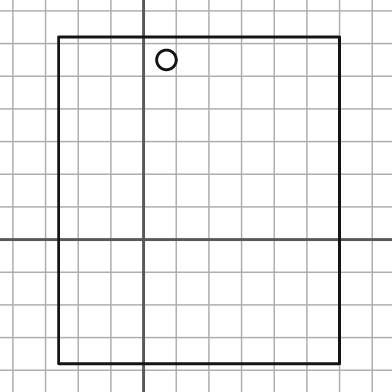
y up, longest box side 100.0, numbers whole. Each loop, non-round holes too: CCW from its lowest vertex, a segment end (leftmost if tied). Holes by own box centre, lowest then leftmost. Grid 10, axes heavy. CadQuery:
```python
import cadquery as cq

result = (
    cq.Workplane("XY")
    .moveTo(-26.0, -38.0)
    .lineTo(60.0, -38.0)
    .lineTo(60.0, 62.0)
    .lineTo(-26.0, 62.0)
    .close()
    .moveTo(7.0, 55.0)
    .circle(3.0)
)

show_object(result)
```